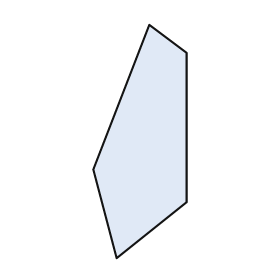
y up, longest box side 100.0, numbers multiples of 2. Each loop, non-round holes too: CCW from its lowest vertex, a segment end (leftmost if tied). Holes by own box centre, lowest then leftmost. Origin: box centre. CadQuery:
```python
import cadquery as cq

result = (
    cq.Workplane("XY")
    .moveTo(-10.0, -50.0)
    .lineTo(20.0, -26.0)
    .lineTo(20.0, 38.0)
    .lineTo(4.0, 50.0)
    .lineTo(-20.0, -12.0)
    .close()
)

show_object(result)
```